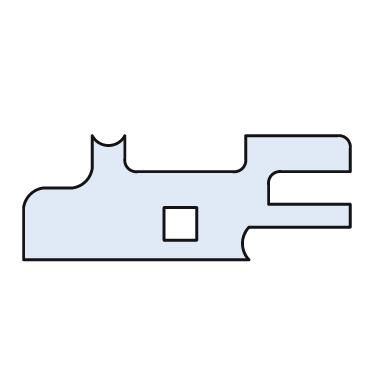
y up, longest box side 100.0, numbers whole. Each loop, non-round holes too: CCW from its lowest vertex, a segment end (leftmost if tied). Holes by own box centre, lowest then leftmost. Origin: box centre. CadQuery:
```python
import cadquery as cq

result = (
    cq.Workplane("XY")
    .moveTo(-50.0, -19.0)
    .lineTo(19.0, -19.0)
    .threePointArc((17.0, -14.0), (19.0, -9.0))
    .lineTo(50.0, -9.0)
    .lineTo(50.0, -2.0)
    .lineTo(25.0, -2.0)
    .lineTo(25.0, 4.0)
    .threePointArc((26.0, 7.0), (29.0, 8.0))
    .lineTo(50.0, 8.0)
    .lineTo(50.0, 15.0)
    .threePointArc((49.0, 18.0), (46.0, 19.0))
    .lineTo(18.0, 19.0)
    .lineTo(18.0, 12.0)
    .threePointArc((17.0, 9.0), (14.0, 8.0))
    .lineTo(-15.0, 8.0)
    .threePointArc((-18.0, 9.0), (-19.0, 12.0))
    .lineTo(-19.0, 19.0)
    .threePointArc((-24.0, 16.0), (-29.0, 19.0))
    .lineTo(-29.0, 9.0)
    .threePointArc((-31.0, 5.0), (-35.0, 3.0))
    .lineTo(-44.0, 3.0)
    .threePointArc((-48.0, 1.0), (-50.0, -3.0))
    .close()
    .moveTo(-7.0, -13.0)
    .lineTo(3.0, -13.0)
    .lineTo(3.0, -3.0)
    .lineTo(-7.0, -3.0)
    .close()
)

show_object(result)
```